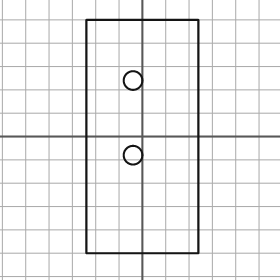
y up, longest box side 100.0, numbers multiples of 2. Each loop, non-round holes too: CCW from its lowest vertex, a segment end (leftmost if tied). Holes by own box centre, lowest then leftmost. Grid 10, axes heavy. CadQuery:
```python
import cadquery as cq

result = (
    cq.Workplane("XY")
    .moveTo(-24.0, -50.0)
    .lineTo(24.0, -50.0)
    .lineTo(24.0, 50.0)
    .lineTo(-24.0, 50.0)
    .close()
    .moveTo(-4.0, -8.0)
    .circle(4.0)
    .moveTo(-4.0, 24.0)
    .circle(4.0)
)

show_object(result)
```